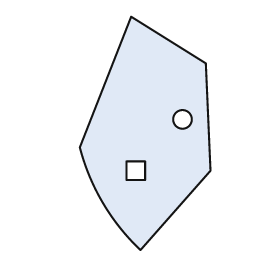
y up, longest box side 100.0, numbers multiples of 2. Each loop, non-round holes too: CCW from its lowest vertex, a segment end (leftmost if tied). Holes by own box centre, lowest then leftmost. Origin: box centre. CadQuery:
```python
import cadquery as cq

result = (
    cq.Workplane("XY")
    .moveTo(-2.0, -50.0)
    .lineTo(28.0, -16.0)
    .lineTo(26.0, 30.0)
    .lineTo(-6.0, 50.0)
    .lineTo(-28.0, -6.0)
    .threePointArc((-18.0, -30.0), (-2.0, -50.0))
    .close()
    .moveTo(-8.0, -20.0)
    .lineTo(0.0, -20.0)
    .lineTo(0.0, -12.0)
    .lineTo(-8.0, -12.0)
    .close()
    .moveTo(16.0, 6.0)
    .circle(4.0)
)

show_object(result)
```